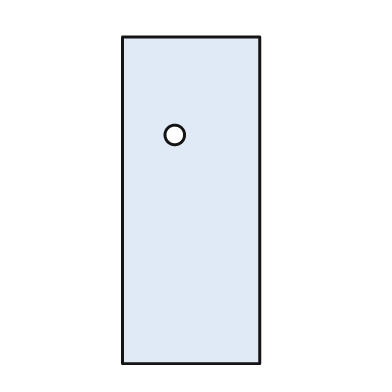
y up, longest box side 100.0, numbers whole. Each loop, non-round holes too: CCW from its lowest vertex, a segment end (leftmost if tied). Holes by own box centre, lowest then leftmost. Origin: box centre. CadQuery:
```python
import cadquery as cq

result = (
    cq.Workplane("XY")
    .moveTo(-21.0, -50.0)
    .lineTo(21.0, -50.0)
    .lineTo(21.0, 50.0)
    .lineTo(-21.0, 50.0)
    .close()
    .moveTo(-5.0, 20.0)
    .circle(3.0)
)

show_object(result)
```